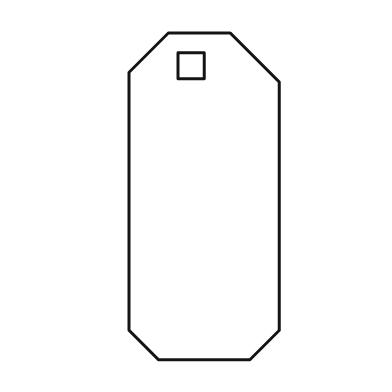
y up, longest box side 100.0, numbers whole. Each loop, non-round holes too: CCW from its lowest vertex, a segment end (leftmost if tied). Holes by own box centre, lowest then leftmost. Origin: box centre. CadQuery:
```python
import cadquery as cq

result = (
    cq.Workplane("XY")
    .moveTo(-14.0, -50.0)
    .lineTo(14.0, -50.0)
    .lineTo(23.0, -41.0)
    .lineTo(23.0, 35.0)
    .lineTo(8.0, 50.0)
    .lineTo(-11.0, 50.0)
    .lineTo(-23.0, 38.0)
    .lineTo(-23.0, -41.0)
    .close()
    .moveTo(-8.0, 36.0)
    .lineTo(0.0, 36.0)
    .lineTo(0.0, 44.0)
    .lineTo(-8.0, 44.0)
    .close()
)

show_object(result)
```